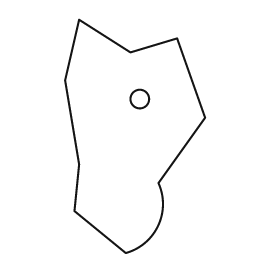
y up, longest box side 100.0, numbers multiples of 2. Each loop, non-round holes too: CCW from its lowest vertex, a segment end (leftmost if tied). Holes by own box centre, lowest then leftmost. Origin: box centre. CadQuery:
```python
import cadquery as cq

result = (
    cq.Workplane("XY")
    .moveTo(-4.0, -50.0)
    .threePointArc((10.0, -38.0), (10.0, -20.0))
    .lineTo(30.0, 8.0)
    .lineTo(18.0, 42.0)
    .lineTo(-2.0, 36.0)
    .lineTo(-24.0, 50.0)
    .lineTo(-30.0, 24.0)
    .lineTo(-24.0, -12.0)
    .lineTo(-26.0, -32.0)
    .close()
    .moveTo(2.0, 16.0)
    .circle(4.0)
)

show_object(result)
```